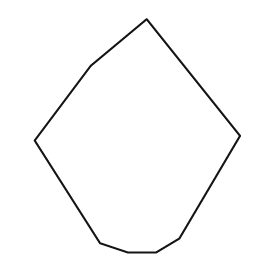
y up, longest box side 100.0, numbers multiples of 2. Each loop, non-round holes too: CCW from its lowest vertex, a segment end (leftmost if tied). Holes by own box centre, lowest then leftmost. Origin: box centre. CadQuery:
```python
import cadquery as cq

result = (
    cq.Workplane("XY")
    .moveTo(-4.0, -50.0)
    .lineTo(8.0, -50.0)
    .lineTo(18.0, -44.0)
    .lineTo(44.0, 0.0)
    .lineTo(4.0, 50.0)
    .lineTo(-20.0, 30.0)
    .lineTo(-44.0, -2.0)
    .lineTo(-16.0, -46.0)
    .close()
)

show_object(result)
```